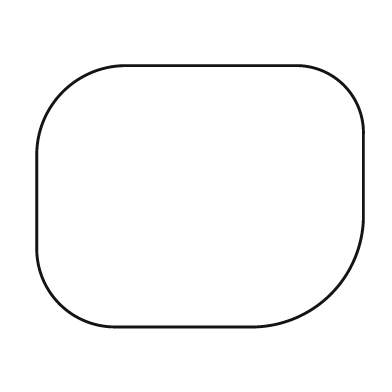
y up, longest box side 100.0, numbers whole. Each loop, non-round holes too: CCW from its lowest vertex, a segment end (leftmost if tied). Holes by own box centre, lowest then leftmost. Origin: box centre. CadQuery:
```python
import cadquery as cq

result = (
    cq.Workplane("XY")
    .moveTo(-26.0, -40.0)
    .lineTo(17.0, -40.0)
    .threePointArc((40.0, -30.0), (50.0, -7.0))
    .lineTo(50.0, 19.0)
    .threePointArc((44.0, 34.0), (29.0, 40.0))
    .lineTo(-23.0, 40.0)
    .threePointArc((-42.0, 32.0), (-50.0, 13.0))
    .lineTo(-50.0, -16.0)
    .threePointArc((-43.0, -33.0), (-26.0, -40.0))
    .close()
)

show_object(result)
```